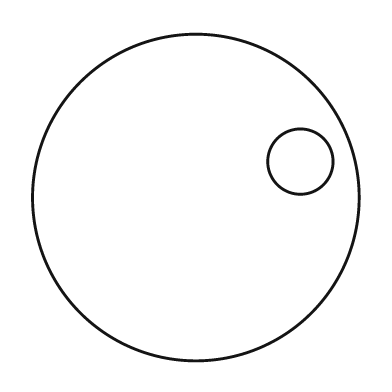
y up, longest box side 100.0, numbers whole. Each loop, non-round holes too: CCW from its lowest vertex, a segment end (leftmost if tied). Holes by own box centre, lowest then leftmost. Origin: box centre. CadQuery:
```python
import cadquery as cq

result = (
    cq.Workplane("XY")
    .moveTo(0.0, 0.0)
    .circle(50.0)
    .moveTo(32.0, 11.0)
    .circle(10.0)
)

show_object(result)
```